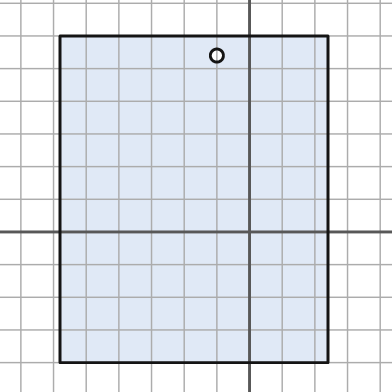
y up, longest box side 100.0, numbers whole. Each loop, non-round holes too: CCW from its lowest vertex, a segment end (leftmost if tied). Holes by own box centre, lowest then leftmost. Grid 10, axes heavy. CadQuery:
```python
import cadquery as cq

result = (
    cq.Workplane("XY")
    .moveTo(-58.0, -40.0)
    .lineTo(24.0, -40.0)
    .lineTo(24.0, 60.0)
    .lineTo(-58.0, 60.0)
    .close()
    .moveTo(-10.0, 54.0)
    .circle(2.0)
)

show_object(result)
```